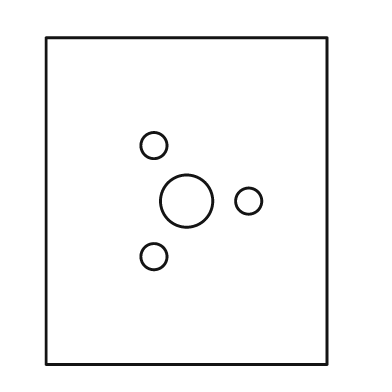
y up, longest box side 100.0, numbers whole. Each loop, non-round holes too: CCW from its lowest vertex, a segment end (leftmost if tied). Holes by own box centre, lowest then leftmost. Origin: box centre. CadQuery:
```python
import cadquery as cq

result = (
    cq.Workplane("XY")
    .moveTo(-43.0, -50.0)
    .lineTo(43.0, -50.0)
    .lineTo(43.0, 50.0)
    .lineTo(-43.0, 50.0)
    .close()
    .moveTo(-10.0, -17.0)
    .circle(4.0)
    .moveTo(0.0, 0.0)
    .circle(8.0)
    .moveTo(19.0, 0.0)
    .circle(4.0)
    .moveTo(-10.0, 17.0)
    .circle(4.0)
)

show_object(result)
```